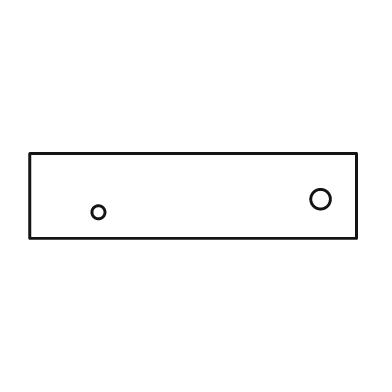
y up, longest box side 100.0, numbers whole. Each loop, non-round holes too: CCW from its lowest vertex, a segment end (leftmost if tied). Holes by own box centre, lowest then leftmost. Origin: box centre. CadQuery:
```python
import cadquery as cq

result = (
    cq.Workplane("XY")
    .moveTo(-50.0, -13.0)
    .lineTo(50.0, -13.0)
    .lineTo(50.0, 13.0)
    .lineTo(-50.0, 13.0)
    .close()
    .moveTo(-29.0, -5.0)
    .circle(2.0)
    .moveTo(39.0, -1.0)
    .circle(3.0)
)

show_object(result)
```